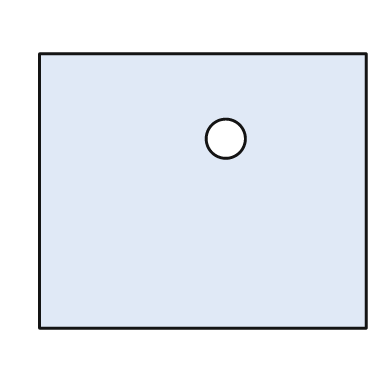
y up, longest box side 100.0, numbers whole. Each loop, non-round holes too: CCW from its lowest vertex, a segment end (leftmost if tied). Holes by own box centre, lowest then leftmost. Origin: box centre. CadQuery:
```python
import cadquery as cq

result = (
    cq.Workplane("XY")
    .moveTo(-50.0, -42.0)
    .lineTo(50.0, -42.0)
    .lineTo(50.0, 42.0)
    .lineTo(-50.0, 42.0)
    .close()
    .moveTo(7.0, 16.0)
    .circle(6.0)
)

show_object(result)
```